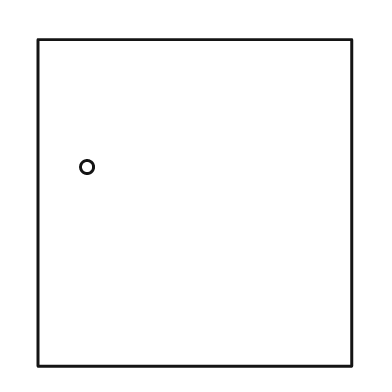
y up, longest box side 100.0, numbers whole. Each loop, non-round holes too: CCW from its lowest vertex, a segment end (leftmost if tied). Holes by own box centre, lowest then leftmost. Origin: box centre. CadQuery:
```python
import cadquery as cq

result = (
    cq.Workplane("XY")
    .moveTo(-48.0, -50.0)
    .lineTo(48.0, -50.0)
    .lineTo(48.0, 50.0)
    .lineTo(-48.0, 50.0)
    .close()
    .moveTo(-33.0, 11.0)
    .circle(2.0)
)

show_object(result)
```